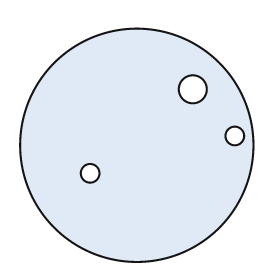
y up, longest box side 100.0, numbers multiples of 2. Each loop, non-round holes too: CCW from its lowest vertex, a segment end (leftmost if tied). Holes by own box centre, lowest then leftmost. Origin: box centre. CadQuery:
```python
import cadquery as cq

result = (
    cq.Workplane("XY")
    .moveTo(0.0, 0.0)
    .circle(50.0)
    .moveTo(-20.0, -12.0)
    .circle(4.0)
    .moveTo(42.0, 4.0)
    .circle(4.0)
    .moveTo(24.0, 24.0)
    .circle(6.0)
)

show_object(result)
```